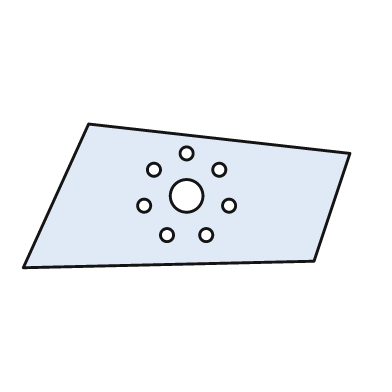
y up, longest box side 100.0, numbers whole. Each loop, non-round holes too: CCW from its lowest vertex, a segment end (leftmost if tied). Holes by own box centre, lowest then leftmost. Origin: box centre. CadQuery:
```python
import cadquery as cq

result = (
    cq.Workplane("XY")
    .moveTo(-50.0, -22.0)
    .lineTo(39.0, -20.0)
    .lineTo(50.0, 13.0)
    .lineTo(-30.0, 22.0)
    .close()
    .moveTo(-6.0, -12.0)
    .circle(2.0)
    .moveTo(6.0, -12.0)
    .circle(2.0)
    .moveTo(-13.0, -3.0)
    .circle(2.0)
    .moveTo(13.0, -3.0)
    .circle(2.0)
    .moveTo(0.0, 0.0)
    .circle(5.0)
    .moveTo(-10.0, 8.0)
    .circle(2.0)
    .moveTo(10.0, 8.0)
    .circle(2.0)
    .moveTo(0.0, 13.0)
    .circle(2.0)
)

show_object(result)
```